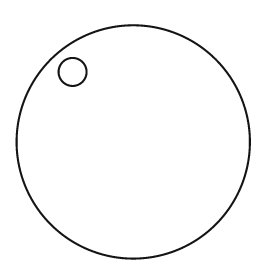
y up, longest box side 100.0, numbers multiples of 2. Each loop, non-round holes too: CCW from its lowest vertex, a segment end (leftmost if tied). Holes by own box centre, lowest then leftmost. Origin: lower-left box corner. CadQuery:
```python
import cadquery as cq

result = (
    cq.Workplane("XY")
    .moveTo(50.0, 50.0)
    .circle(50.0)
    .moveTo(24.0, 80.0)
    .circle(6.0)
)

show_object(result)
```